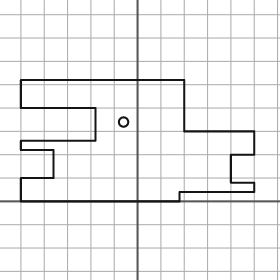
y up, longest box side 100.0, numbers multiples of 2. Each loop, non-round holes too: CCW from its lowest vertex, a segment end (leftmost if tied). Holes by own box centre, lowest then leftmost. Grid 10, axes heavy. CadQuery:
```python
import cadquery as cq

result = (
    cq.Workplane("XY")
    .moveTo(-50.0, 0.0)
    .lineTo(18.0, 0.0)
    .lineTo(18.0, 4.0)
    .lineTo(50.0, 4.0)
    .lineTo(50.0, 8.0)
    .lineTo(40.0, 8.0)
    .lineTo(40.0, 20.0)
    .lineTo(50.0, 20.0)
    .lineTo(50.0, 30.0)
    .lineTo(20.0, 30.0)
    .lineTo(20.0, 52.0)
    .lineTo(-50.0, 52.0)
    .lineTo(-50.0, 40.0)
    .lineTo(-18.0, 40.0)
    .lineTo(-18.0, 26.0)
    .lineTo(-50.0, 26.0)
    .lineTo(-50.0, 22.0)
    .lineTo(-36.0, 22.0)
    .lineTo(-36.0, 10.0)
    .lineTo(-50.0, 10.0)
    .close()
    .moveTo(-6.0, 34.0)
    .circle(2.0)
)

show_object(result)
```